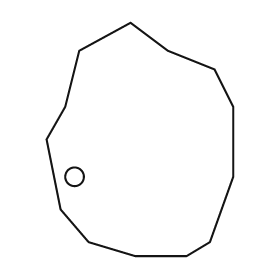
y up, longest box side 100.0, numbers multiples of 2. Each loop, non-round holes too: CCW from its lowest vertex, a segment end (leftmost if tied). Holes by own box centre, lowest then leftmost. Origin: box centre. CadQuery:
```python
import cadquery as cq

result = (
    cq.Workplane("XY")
    .moveTo(-2.0, -50.0)
    .lineTo(20.0, -50.0)
    .lineTo(30.0, -44.0)
    .lineTo(40.0, -16.0)
    .lineTo(40.0, 14.0)
    .lineTo(32.0, 30.0)
    .lineTo(12.0, 38.0)
    .lineTo(-4.0, 50.0)
    .lineTo(-26.0, 38.0)
    .lineTo(-32.0, 14.0)
    .lineTo(-40.0, 0.0)
    .lineTo(-34.0, -30.0)
    .lineTo(-22.0, -44.0)
    .close()
    .moveTo(-28.0, -16.0)
    .circle(4.0)
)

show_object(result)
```